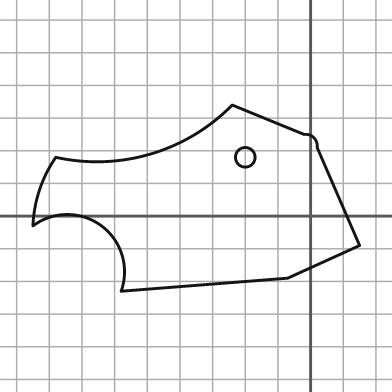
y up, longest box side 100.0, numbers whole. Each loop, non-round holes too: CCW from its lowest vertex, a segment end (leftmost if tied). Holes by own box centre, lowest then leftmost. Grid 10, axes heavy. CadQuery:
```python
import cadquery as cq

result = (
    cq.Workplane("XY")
    .moveTo(-58.0, -23.0)
    .lineTo(-7.0, -19.0)
    .lineTo(15.0, -9.0)
    .lineTo(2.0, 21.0)
    .threePointArc((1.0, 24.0), (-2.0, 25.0))
    .lineTo(-24.0, 34.0)
    .threePointArc((-49.0, 19.0), (-78.0, 18.0))
    .threePointArc((-83.0, 8.0), (-85.0, -3.0))
    .threePointArc((-64.0, -3.0), (-58.0, -23.0))
    .close()
    .moveTo(-20.0, 18.0)
    .circle(3.0)
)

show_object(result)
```